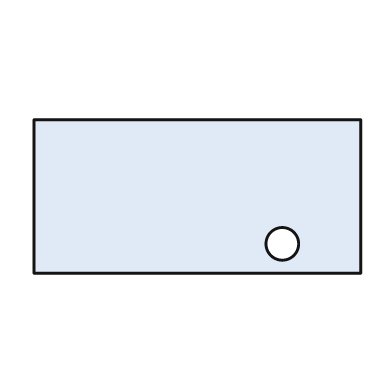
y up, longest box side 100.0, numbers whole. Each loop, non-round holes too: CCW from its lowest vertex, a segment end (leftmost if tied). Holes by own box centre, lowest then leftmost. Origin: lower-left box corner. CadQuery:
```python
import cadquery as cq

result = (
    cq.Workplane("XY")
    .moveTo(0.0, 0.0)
    .lineTo(100.0, 0.0)
    .lineTo(100.0, 47.0)
    .lineTo(0.0, 47.0)
    .close()
    .moveTo(76.0, 9.0)
    .circle(5.0)
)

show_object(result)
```